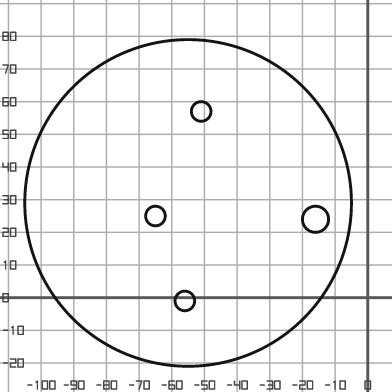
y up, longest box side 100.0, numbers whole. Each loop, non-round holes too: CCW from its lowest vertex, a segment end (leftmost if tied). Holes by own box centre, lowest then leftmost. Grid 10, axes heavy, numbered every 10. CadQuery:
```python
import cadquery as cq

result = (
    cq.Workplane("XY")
    .moveTo(-55.0, 29.0)
    .circle(50.0)
    .moveTo(-56.0, -1.0)
    .circle(3.0)
    .moveTo(-16.0, 24.0)
    .circle(4.0)
    .moveTo(-65.0, 25.0)
    .circle(3.0)
    .moveTo(-51.0, 57.0)
    .circle(3.0)
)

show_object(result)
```